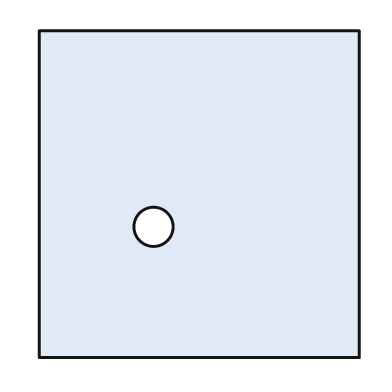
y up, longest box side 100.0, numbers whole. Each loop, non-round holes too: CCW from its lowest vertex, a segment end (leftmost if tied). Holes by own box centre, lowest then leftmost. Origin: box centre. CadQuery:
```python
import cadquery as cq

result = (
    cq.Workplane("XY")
    .moveTo(-49.0, -50.0)
    .lineTo(49.0, -50.0)
    .lineTo(49.0, 50.0)
    .lineTo(-49.0, 50.0)
    .close()
    .moveTo(-14.0, -10.0)
    .circle(6.0)
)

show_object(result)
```